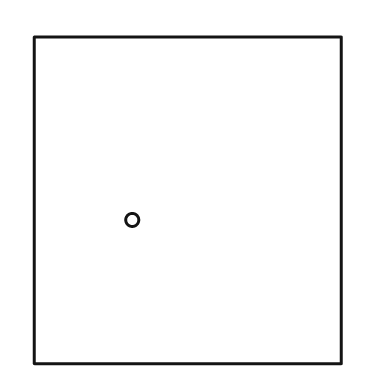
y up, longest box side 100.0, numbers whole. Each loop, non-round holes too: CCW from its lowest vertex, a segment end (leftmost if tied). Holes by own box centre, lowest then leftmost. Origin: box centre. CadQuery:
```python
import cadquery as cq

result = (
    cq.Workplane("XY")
    .moveTo(-47.0, -50.0)
    .lineTo(47.0, -50.0)
    .lineTo(47.0, 50.0)
    .lineTo(-47.0, 50.0)
    .close()
    .moveTo(-17.0, -6.0)
    .circle(2.0)
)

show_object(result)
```